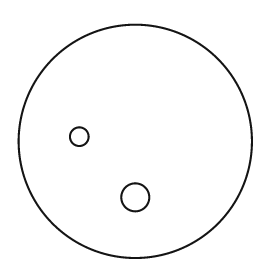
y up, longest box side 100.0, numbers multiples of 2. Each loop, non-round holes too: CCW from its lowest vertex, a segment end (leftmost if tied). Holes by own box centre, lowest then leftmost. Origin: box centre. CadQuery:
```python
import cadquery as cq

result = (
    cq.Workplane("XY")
    .moveTo(0.0, 0.0)
    .circle(50.0)
    .moveTo(0.0, -24.0)
    .circle(6.0)
    .moveTo(-24.0, 2.0)
    .circle(4.0)
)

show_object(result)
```